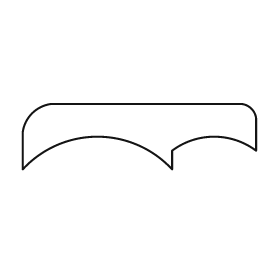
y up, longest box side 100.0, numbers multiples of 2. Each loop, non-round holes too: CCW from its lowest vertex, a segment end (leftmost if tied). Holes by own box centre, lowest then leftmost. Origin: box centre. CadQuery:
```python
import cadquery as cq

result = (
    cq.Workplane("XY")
    .moveTo(-50.0, -14.0)
    .threePointArc((-18.0, 0.0), (14.0, -14.0))
    .lineTo(14.0, -6.0)
    .threePointArc((32.0, 0.0), (50.0, -6.0))
    .lineTo(50.0, 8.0)
    .threePointArc((48.0, 12.0), (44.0, 14.0))
    .lineTo(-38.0, 14.0)
    .threePointArc((-46.0, 10.0), (-50.0, 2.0))
    .close()
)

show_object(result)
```